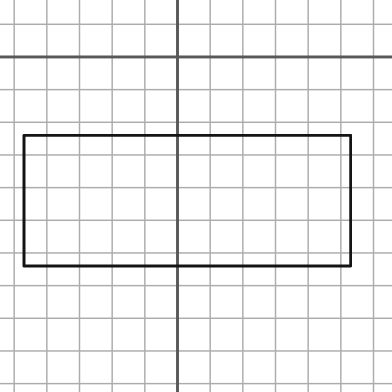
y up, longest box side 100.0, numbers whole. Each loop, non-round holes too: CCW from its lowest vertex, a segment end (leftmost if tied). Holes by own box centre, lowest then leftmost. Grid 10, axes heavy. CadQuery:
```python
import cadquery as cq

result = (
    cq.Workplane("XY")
    .moveTo(-47.0, -64.0)
    .lineTo(53.0, -64.0)
    .lineTo(53.0, -24.0)
    .lineTo(-47.0, -24.0)
    .close()
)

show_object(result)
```